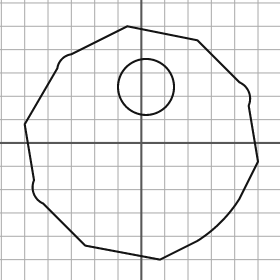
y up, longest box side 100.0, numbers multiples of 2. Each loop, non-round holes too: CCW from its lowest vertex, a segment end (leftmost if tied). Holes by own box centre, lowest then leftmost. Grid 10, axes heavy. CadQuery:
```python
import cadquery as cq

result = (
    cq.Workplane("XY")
    .moveTo(8.0, -50.0)
    .lineTo(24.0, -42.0)
    .threePointArc((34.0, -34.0), (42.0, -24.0))
    .lineTo(50.0, -8.0)
    .lineTo(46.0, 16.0)
    .threePointArc((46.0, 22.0), (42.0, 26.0))
    .lineTo(24.0, 44.0)
    .lineTo(-6.0, 50.0)
    .lineTo(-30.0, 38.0)
    .threePointArc((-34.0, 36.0), (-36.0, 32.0))
    .lineTo(-50.0, 8.0)
    .lineTo(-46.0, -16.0)
    .threePointArc((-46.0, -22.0), (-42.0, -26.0))
    .lineTo(-24.0, -44.0)
    .close()
    .moveTo(2.0, 24.0)
    .circle(12.0)
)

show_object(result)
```